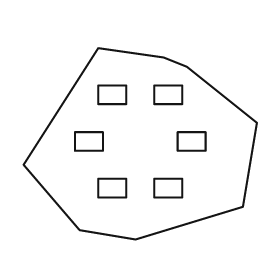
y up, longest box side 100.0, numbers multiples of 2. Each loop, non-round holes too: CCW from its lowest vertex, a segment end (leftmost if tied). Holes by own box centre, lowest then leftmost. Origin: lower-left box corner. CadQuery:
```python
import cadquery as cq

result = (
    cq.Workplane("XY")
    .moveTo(48.0, 0.0)
    .lineTo(94.0, 14.0)
    .lineTo(100.0, 50.0)
    .lineTo(70.0, 74.0)
    .lineTo(60.0, 78.0)
    .lineTo(32.0, 82.0)
    .lineTo(0.0, 32.0)
    .lineTo(24.0, 4.0)
    .close()
    .moveTo(32.0, 18.0)
    .lineTo(44.0, 18.0)
    .lineTo(44.0, 26.0)
    .lineTo(32.0, 26.0)
    .close()
    .moveTo(56.0, 18.0)
    .lineTo(68.0, 18.0)
    .lineTo(68.0, 26.0)
    .lineTo(56.0, 26.0)
    .close()
    .moveTo(22.0, 38.0)
    .lineTo(34.0, 38.0)
    .lineTo(34.0, 46.0)
    .lineTo(22.0, 46.0)
    .close()
    .moveTo(66.0, 38.0)
    .lineTo(78.0, 38.0)
    .lineTo(78.0, 46.0)
    .lineTo(66.0, 46.0)
    .close()
    .moveTo(32.0, 58.0)
    .lineTo(44.0, 58.0)
    .lineTo(44.0, 66.0)
    .lineTo(32.0, 66.0)
    .close()
    .moveTo(56.0, 58.0)
    .lineTo(68.0, 58.0)
    .lineTo(68.0, 66.0)
    .lineTo(56.0, 66.0)
    .close()
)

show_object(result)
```